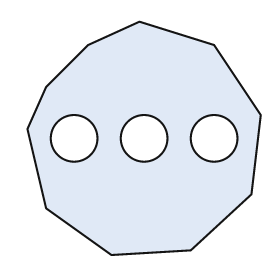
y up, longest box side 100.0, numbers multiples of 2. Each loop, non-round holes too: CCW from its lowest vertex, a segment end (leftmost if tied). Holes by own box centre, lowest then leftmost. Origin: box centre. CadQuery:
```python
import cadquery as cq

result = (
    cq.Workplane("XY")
    .moveTo(-14.0, -50.0)
    .lineTo(20.0, -48.0)
    .lineTo(46.0, -24.0)
    .lineTo(50.0, 10.0)
    .lineTo(30.0, 40.0)
    .lineTo(-2.0, 50.0)
    .lineTo(-24.0, 40.0)
    .lineTo(-42.0, 22.0)
    .lineTo(-50.0, 4.0)
    .lineTo(-42.0, -30.0)
    .close()
    .moveTo(-30.0, 0.0)
    .circle(10.0)
    .moveTo(0.0, 0.0)
    .circle(10.0)
    .moveTo(30.0, 0.0)
    .circle(10.0)
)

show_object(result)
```